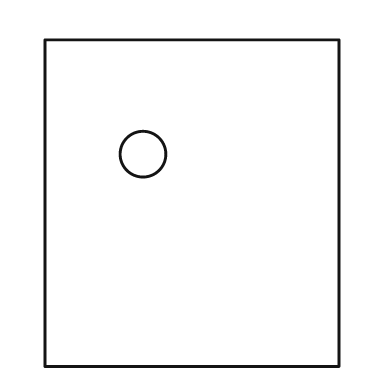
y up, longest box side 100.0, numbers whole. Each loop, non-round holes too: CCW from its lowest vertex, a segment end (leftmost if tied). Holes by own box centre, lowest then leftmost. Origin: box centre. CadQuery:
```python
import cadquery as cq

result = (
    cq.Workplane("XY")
    .moveTo(-45.0, -50.0)
    .lineTo(45.0, -50.0)
    .lineTo(45.0, 50.0)
    .lineTo(-45.0, 50.0)
    .close()
    .moveTo(-15.0, 15.0)
    .circle(7.0)
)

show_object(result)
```